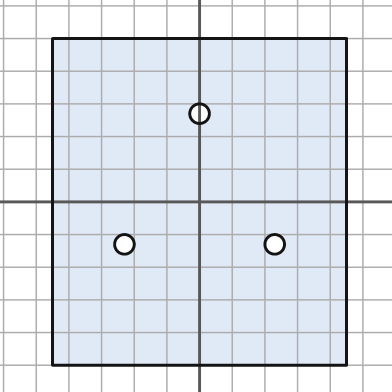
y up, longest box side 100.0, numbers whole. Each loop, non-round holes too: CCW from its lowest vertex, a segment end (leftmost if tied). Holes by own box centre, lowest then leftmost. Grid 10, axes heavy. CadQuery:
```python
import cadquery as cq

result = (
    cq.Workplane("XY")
    .moveTo(-45.0, -50.0)
    .lineTo(45.0, -50.0)
    .lineTo(45.0, 50.0)
    .lineTo(-45.0, 50.0)
    .close()
    .moveTo(-23.0, -13.0)
    .circle(3.0)
    .moveTo(23.0, -13.0)
    .circle(3.0)
    .moveTo(0.0, 27.0)
    .circle(3.0)
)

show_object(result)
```